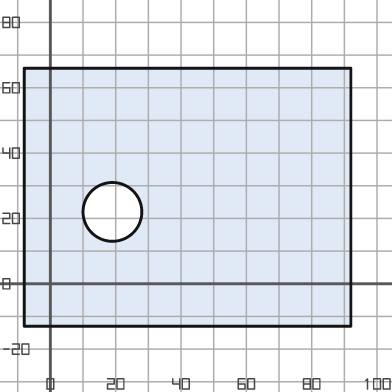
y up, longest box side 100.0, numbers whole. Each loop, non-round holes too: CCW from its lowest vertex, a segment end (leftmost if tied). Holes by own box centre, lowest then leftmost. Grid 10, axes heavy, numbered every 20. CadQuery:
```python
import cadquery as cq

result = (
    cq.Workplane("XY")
    .moveTo(-8.0, -13.0)
    .lineTo(92.0, -13.0)
    .lineTo(92.0, 66.0)
    .lineTo(-8.0, 66.0)
    .close()
    .moveTo(19.0, 22.0)
    .circle(9.0)
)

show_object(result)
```